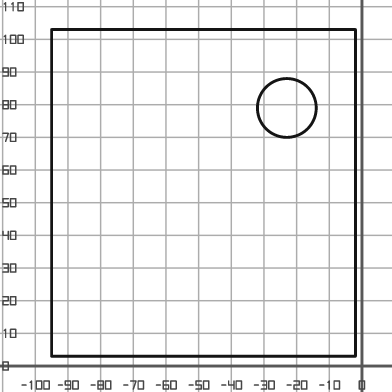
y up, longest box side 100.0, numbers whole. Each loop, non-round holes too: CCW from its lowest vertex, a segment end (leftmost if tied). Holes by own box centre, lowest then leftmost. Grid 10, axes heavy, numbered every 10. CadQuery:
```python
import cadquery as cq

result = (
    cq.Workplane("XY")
    .moveTo(-95.0, 3.0)
    .lineTo(-2.0, 3.0)
    .lineTo(-2.0, 103.0)
    .lineTo(-95.0, 103.0)
    .close()
    .moveTo(-23.0, 79.0)
    .circle(9.0)
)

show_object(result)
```